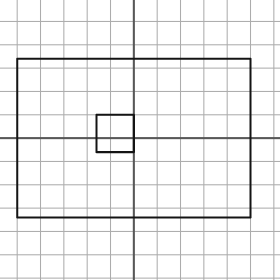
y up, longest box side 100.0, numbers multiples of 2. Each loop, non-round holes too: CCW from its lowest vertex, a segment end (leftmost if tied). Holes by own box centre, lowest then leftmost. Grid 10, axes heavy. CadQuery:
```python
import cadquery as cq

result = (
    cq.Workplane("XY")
    .moveTo(-50.0, -34.0)
    .lineTo(50.0, -34.0)
    .lineTo(50.0, 34.0)
    .lineTo(-50.0, 34.0)
    .close()
    .moveTo(-16.0, -6.0)
    .lineTo(0.0, -6.0)
    .lineTo(0.0, 10.0)
    .lineTo(-16.0, 10.0)
    .close()
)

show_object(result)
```